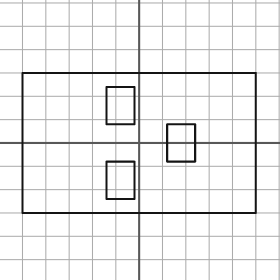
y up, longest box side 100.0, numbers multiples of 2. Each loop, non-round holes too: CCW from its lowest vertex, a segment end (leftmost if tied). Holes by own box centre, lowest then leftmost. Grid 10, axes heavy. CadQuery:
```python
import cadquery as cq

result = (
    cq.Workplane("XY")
    .moveTo(-50.0, -30.0)
    .lineTo(50.0, -30.0)
    .lineTo(50.0, 30.0)
    .lineTo(-50.0, 30.0)
    .close()
    .moveTo(-14.0, -24.0)
    .lineTo(-2.0, -24.0)
    .lineTo(-2.0, -8.0)
    .lineTo(-14.0, -8.0)
    .close()
    .moveTo(12.0, -8.0)
    .lineTo(24.0, -8.0)
    .lineTo(24.0, 8.0)
    .lineTo(12.0, 8.0)
    .close()
    .moveTo(-14.0, 8.0)
    .lineTo(-2.0, 8.0)
    .lineTo(-2.0, 24.0)
    .lineTo(-14.0, 24.0)
    .close()
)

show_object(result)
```